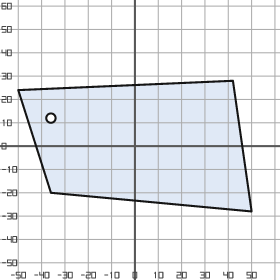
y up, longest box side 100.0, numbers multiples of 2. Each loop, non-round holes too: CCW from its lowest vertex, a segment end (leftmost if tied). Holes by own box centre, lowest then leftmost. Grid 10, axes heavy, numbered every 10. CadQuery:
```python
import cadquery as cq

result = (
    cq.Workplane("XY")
    .moveTo(50.0, -28.0)
    .lineTo(42.0, 28.0)
    .lineTo(-50.0, 24.0)
    .lineTo(-36.0, -20.0)
    .close()
    .moveTo(-36.0, 12.0)
    .circle(2.0)
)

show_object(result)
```